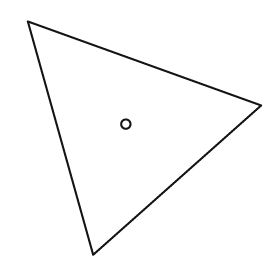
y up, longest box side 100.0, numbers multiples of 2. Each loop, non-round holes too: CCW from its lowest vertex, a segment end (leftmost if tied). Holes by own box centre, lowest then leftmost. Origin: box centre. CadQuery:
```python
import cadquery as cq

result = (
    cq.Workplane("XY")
    .moveTo(-22.0, -50.0)
    .lineTo(50.0, 14.0)
    .lineTo(-50.0, 50.0)
    .close()
    .moveTo(-8.0, 6.0)
    .circle(2.0)
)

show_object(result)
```